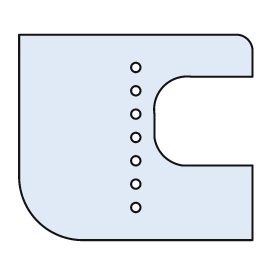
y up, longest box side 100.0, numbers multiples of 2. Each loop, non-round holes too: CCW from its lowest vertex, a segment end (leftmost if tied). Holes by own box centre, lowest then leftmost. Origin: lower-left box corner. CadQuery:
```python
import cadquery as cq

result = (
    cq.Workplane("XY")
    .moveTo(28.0, 0.0)
    .lineTo(100.0, 0.0)
    .lineTo(100.0, 32.0)
    .lineTo(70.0, 32.0)
    .threePointArc((62.0, 36.0), (58.0, 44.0))
    .lineTo(58.0, 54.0)
    .threePointArc((62.0, 66.0), (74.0, 70.0))
    .lineTo(100.0, 70.0)
    .lineTo(100.0, 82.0)
    .threePointArc((98.0, 86.0), (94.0, 88.0))
    .lineTo(0.0, 88.0)
    .lineTo(0.0, 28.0)
    .threePointArc((8.0, 8.0), (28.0, 0.0))
    .close()
    .moveTo(50.0, 14.0)
    .circle(2.0)
    .moveTo(50.0, 24.0)
    .circle(2.0)
    .moveTo(50.0, 34.0)
    .circle(2.0)
    .moveTo(50.0, 44.0)
    .circle(2.0)
    .moveTo(50.0, 54.0)
    .circle(2.0)
    .moveTo(50.0, 64.0)
    .circle(2.0)
    .moveTo(50.0, 74.0)
    .circle(2.0)
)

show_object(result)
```